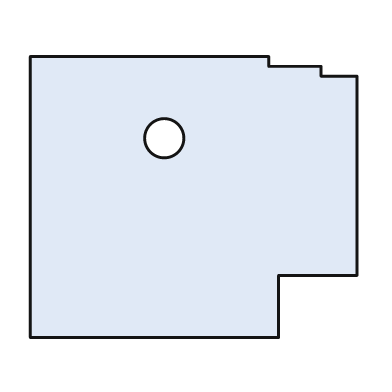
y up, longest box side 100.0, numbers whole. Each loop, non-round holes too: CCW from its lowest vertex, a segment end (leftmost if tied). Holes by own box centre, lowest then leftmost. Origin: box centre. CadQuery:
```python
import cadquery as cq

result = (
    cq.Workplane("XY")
    .moveTo(-50.0, -43.0)
    .lineTo(26.0, -43.0)
    .lineTo(26.0, -24.0)
    .lineTo(50.0, -24.0)
    .lineTo(50.0, 37.0)
    .lineTo(39.0, 37.0)
    .lineTo(39.0, 40.0)
    .lineTo(23.0, 40.0)
    .lineTo(23.0, 43.0)
    .lineTo(-50.0, 43.0)
    .close()
    .moveTo(-9.0, 18.0)
    .circle(6.0)
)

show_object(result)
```